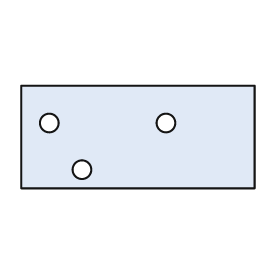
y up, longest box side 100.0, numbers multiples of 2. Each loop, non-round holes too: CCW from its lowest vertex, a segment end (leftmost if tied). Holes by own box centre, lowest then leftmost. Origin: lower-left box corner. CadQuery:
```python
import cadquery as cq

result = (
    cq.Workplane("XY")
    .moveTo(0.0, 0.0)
    .lineTo(100.0, 0.0)
    .lineTo(100.0, 44.0)
    .lineTo(0.0, 44.0)
    .close()
    .moveTo(26.0, 8.0)
    .circle(4.0)
    .moveTo(12.0, 28.0)
    .circle(4.0)
    .moveTo(62.0, 28.0)
    .circle(4.0)
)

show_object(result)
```